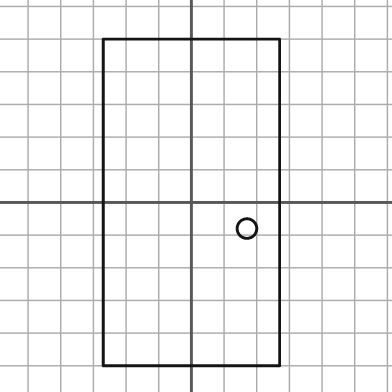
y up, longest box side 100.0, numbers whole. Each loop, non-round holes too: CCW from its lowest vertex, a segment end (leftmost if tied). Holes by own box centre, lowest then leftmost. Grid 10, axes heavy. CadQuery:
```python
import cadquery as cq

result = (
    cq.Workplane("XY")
    .moveTo(-27.0, -50.0)
    .lineTo(27.0, -50.0)
    .lineTo(27.0, 50.0)
    .lineTo(-27.0, 50.0)
    .close()
    .moveTo(17.0, -8.0)
    .circle(3.0)
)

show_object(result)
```